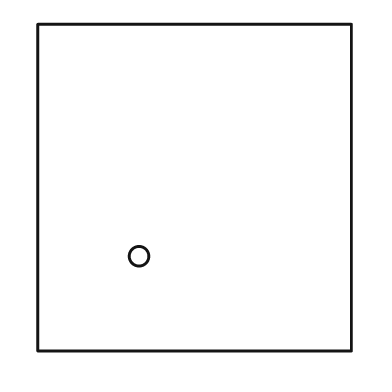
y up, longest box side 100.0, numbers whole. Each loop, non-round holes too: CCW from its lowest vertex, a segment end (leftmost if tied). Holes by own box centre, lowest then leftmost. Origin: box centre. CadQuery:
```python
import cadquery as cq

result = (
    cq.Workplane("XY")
    .moveTo(-48.0, -50.0)
    .lineTo(48.0, -50.0)
    .lineTo(48.0, 50.0)
    .lineTo(-48.0, 50.0)
    .close()
    .moveTo(-17.0, -21.0)
    .circle(3.0)
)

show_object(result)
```